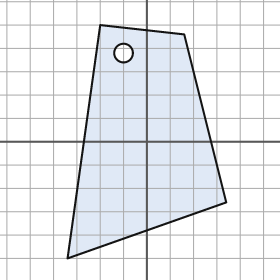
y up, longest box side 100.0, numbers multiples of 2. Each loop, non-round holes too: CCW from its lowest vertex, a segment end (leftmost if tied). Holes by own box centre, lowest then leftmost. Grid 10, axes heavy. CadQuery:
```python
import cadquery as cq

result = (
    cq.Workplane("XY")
    .moveTo(-34.0, -50.0)
    .lineTo(34.0, -26.0)
    .lineTo(16.0, 46.0)
    .lineTo(-20.0, 50.0)
    .close()
    .moveTo(-10.0, 38.0)
    .circle(4.0)
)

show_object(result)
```